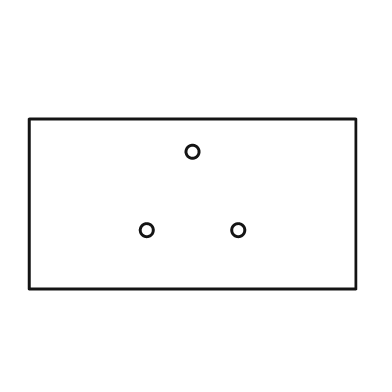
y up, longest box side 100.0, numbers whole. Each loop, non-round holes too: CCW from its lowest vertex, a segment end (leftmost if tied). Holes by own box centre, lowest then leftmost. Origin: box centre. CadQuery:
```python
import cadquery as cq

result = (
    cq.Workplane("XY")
    .moveTo(-50.0, -26.0)
    .lineTo(50.0, -26.0)
    .lineTo(50.0, 26.0)
    .lineTo(-50.0, 26.0)
    .close()
    .moveTo(-14.0, -8.0)
    .circle(2.0)
    .moveTo(14.0, -8.0)
    .circle(2.0)
    .moveTo(0.0, 16.0)
    .circle(2.0)
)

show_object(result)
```